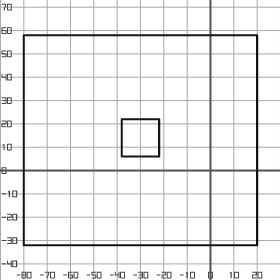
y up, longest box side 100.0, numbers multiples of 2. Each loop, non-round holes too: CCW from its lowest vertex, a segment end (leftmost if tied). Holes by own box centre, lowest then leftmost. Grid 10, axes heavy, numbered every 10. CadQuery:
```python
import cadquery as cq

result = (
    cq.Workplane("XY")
    .moveTo(-80.0, -32.0)
    .lineTo(20.0, -32.0)
    .lineTo(20.0, 58.0)
    .lineTo(-80.0, 58.0)
    .close()
    .moveTo(-38.0, 6.0)
    .lineTo(-22.0, 6.0)
    .lineTo(-22.0, 22.0)
    .lineTo(-38.0, 22.0)
    .close()
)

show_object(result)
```